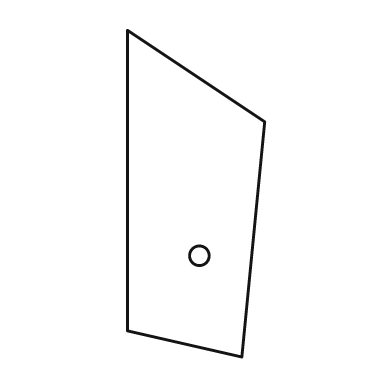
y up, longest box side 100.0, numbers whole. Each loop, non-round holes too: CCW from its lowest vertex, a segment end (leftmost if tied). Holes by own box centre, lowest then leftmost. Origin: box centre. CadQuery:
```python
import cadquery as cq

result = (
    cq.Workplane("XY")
    .moveTo(14.0, -50.0)
    .lineTo(21.0, 22.0)
    .lineTo(-21.0, 50.0)
    .lineTo(-21.0, -42.0)
    .close()
    .moveTo(1.0, -19.0)
    .circle(3.0)
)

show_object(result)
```